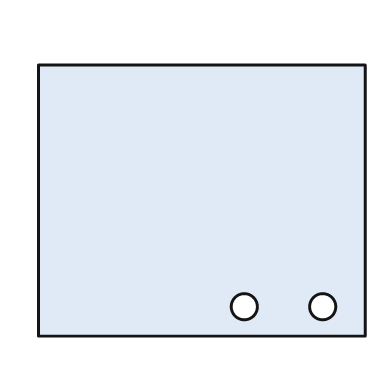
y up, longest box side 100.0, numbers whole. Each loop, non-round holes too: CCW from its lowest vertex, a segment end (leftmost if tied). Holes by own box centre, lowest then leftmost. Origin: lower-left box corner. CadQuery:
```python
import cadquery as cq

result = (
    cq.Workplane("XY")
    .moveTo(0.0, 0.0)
    .lineTo(100.0, 0.0)
    .lineTo(100.0, 83.0)
    .lineTo(0.0, 83.0)
    .close()
    .moveTo(63.0, 9.0)
    .circle(4.0)
    .moveTo(87.0, 9.0)
    .circle(4.0)
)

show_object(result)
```